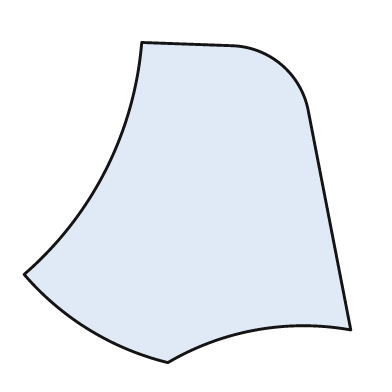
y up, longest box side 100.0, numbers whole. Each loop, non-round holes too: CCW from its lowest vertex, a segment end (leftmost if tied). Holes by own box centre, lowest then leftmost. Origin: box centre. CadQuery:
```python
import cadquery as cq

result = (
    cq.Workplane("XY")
    .moveTo(-6.0, -49.0)
    .threePointArc((21.0, -39.0), (50.0, -39.0))
    .lineTo(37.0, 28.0)
    .threePointArc((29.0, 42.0), (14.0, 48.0))
    .lineTo(-14.0, 49.0)
    .threePointArc((-25.0, 10.0), (-50.0, -22.0))
    .threePointArc((-30.0, -39.0), (-6.0, -49.0))
    .close()
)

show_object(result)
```